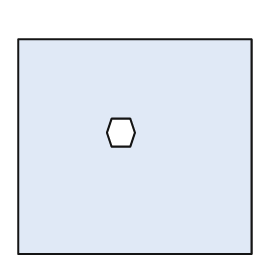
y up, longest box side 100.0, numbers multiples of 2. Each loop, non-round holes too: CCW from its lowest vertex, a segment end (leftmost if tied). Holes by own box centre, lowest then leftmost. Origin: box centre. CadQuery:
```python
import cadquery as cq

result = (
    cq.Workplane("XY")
    .moveTo(-50.0, -46.0)
    .lineTo(50.0, -46.0)
    .lineTo(50.0, 46.0)
    .lineTo(-50.0, 46.0)
    .close()
    .moveTo(-10.0, 0.0)
    .lineTo(-2.0, 0.0)
    .lineTo(0.0, 6.0)
    .lineTo(-2.0, 12.0)
    .lineTo(-10.0, 12.0)
    .lineTo(-12.0, 6.0)
    .close()
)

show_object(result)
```